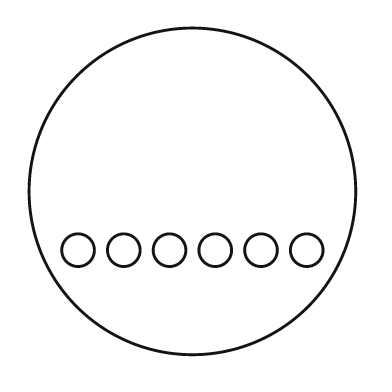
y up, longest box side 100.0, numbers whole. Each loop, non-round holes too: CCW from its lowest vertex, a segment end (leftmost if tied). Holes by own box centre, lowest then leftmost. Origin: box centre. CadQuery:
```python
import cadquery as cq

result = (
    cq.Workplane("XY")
    .moveTo(0.0, 0.0)
    .circle(50.0)
    .moveTo(-35.0, -18.0)
    .circle(5.0)
    .moveTo(-21.0, -18.0)
    .circle(5.0)
    .moveTo(-7.0, -18.0)
    .circle(5.0)
    .moveTo(7.0, -18.0)
    .circle(5.0)
    .moveTo(21.0, -18.0)
    .circle(5.0)
    .moveTo(35.0, -18.0)
    .circle(5.0)
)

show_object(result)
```